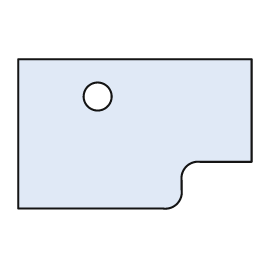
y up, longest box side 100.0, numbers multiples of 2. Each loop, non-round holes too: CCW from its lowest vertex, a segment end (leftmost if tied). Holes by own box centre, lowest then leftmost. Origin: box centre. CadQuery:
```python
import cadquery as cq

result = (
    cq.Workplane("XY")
    .moveTo(-50.0, -32.0)
    .lineTo(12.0, -32.0)
    .threePointArc((18.0, -30.0), (20.0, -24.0))
    .lineTo(20.0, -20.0)
    .threePointArc((22.0, -14.0), (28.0, -12.0))
    .lineTo(50.0, -12.0)
    .lineTo(50.0, 32.0)
    .lineTo(-50.0, 32.0)
    .close()
    .moveTo(-16.0, 16.0)
    .circle(6.0)
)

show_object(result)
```